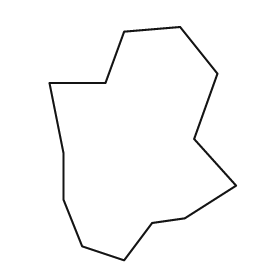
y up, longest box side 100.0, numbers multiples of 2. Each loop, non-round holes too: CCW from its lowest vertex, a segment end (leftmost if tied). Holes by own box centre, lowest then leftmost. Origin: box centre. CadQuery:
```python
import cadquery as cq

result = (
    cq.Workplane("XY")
    .moveTo(-8.0, -50.0)
    .lineTo(4.0, -34.0)
    .lineTo(18.0, -32.0)
    .lineTo(40.0, -18.0)
    .lineTo(22.0, 2.0)
    .lineTo(32.0, 30.0)
    .lineTo(16.0, 50.0)
    .lineTo(-8.0, 48.0)
    .lineTo(-16.0, 26.0)
    .lineTo(-40.0, 26.0)
    .lineTo(-34.0, -4.0)
    .lineTo(-34.0, -24.0)
    .lineTo(-26.0, -44.0)
    .close()
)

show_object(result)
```